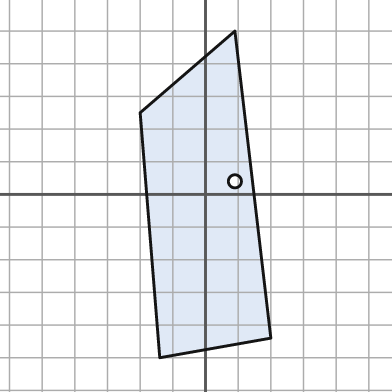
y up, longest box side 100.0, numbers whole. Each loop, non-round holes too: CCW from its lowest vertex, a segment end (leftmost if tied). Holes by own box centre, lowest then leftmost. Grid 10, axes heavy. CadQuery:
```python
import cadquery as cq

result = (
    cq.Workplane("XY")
    .moveTo(-14.0, -50.0)
    .lineTo(20.0, -44.0)
    .lineTo(9.0, 50.0)
    .lineTo(-20.0, 25.0)
    .close()
    .moveTo(9.0, 4.0)
    .circle(2.0)
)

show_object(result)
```